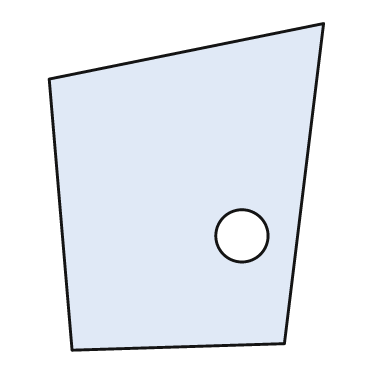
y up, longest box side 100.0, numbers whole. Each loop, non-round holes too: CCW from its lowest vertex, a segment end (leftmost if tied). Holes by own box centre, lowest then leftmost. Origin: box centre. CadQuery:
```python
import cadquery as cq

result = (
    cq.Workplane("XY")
    .moveTo(-35.0, -50.0)
    .lineTo(30.0, -48.0)
    .lineTo(42.0, 50.0)
    .lineTo(-42.0, 33.0)
    .close()
    .moveTo(17.0, -15.0)
    .circle(8.0)
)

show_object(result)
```